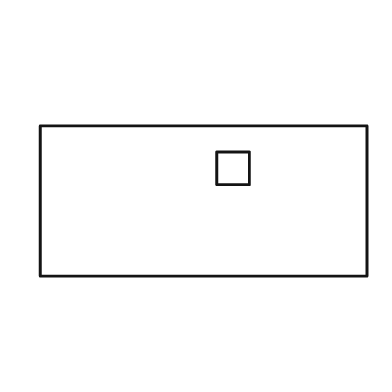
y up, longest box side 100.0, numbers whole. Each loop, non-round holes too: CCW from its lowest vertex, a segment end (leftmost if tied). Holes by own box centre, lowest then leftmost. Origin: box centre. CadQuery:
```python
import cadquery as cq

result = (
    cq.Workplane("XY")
    .moveTo(-50.0, -23.0)
    .lineTo(50.0, -23.0)
    .lineTo(50.0, 23.0)
    .lineTo(-50.0, 23.0)
    .close()
    .moveTo(4.0, 5.0)
    .lineTo(14.0, 5.0)
    .lineTo(14.0, 15.0)
    .lineTo(4.0, 15.0)
    .close()
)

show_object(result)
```